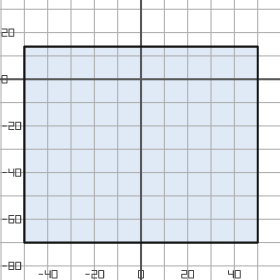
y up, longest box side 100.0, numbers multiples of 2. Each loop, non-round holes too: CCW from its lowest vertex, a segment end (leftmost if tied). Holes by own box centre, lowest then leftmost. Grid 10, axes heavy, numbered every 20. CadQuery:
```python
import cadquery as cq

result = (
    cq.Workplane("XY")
    .moveTo(-50.0, -70.0)
    .lineTo(50.0, -70.0)
    .lineTo(50.0, 14.0)
    .lineTo(-50.0, 14.0)
    .close()
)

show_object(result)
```